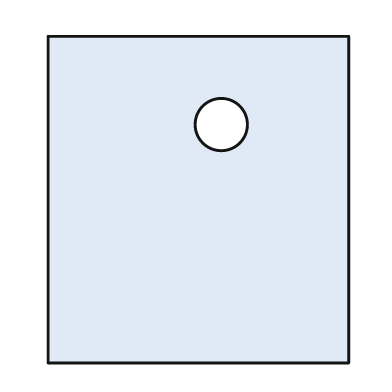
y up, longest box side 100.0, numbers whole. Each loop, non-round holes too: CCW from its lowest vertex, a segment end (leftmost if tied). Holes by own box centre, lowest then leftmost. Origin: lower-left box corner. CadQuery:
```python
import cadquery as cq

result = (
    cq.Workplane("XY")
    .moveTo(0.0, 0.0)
    .lineTo(92.0, 0.0)
    .lineTo(92.0, 100.0)
    .lineTo(0.0, 100.0)
    .close()
    .moveTo(53.0, 73.0)
    .circle(8.0)
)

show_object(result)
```